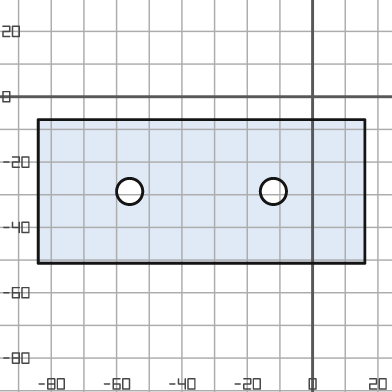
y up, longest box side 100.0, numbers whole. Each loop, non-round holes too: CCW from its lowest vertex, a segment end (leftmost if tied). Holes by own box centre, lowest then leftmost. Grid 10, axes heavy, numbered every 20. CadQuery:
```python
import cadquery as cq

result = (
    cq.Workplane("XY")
    .moveTo(-84.0, -51.0)
    .lineTo(16.0, -51.0)
    .lineTo(16.0, -7.0)
    .lineTo(-84.0, -7.0)
    .close()
    .moveTo(-56.0, -29.0)
    .circle(4.0)
    .moveTo(-12.0, -29.0)
    .circle(4.0)
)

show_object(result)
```